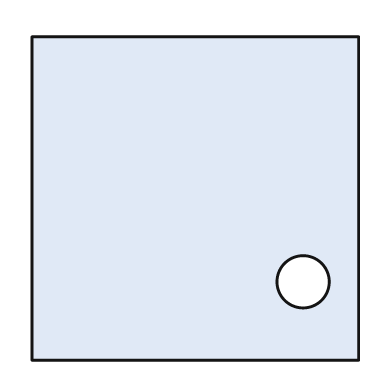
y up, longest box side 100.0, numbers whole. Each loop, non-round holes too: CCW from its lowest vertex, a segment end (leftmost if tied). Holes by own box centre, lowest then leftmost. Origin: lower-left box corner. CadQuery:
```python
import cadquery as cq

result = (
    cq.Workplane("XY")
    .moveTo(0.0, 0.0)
    .lineTo(100.0, 0.0)
    .lineTo(100.0, 99.0)
    .lineTo(0.0, 99.0)
    .close()
    .moveTo(83.0, 24.0)
    .circle(8.0)
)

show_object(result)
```